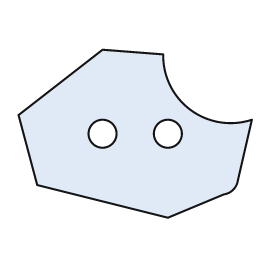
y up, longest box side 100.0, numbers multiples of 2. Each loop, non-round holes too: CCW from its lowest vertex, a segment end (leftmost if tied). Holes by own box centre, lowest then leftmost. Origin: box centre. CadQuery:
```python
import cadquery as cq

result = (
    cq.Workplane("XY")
    .moveTo(14.0, -36.0)
    .lineTo(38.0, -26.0)
    .threePointArc((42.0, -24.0), (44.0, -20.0))
    .lineTo(50.0, 6.0)
    .threePointArc((24.0, 10.0), (12.0, 34.0))
    .lineTo(-14.0, 36.0)
    .lineTo(-50.0, 8.0)
    .lineTo(-42.0, -22.0)
    .close()
    .moveTo(-14.0, 0.0)
    .circle(6.0)
    .moveTo(14.0, 0.0)
    .circle(6.0)
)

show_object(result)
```